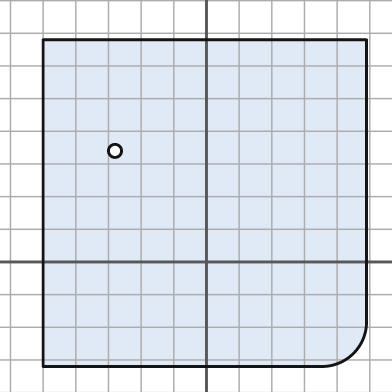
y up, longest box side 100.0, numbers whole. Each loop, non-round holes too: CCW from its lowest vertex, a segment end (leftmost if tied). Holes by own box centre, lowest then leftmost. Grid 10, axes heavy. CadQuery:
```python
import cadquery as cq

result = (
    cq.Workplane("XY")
    .moveTo(-50.0, -32.0)
    .lineTo(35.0, -32.0)
    .threePointArc((45.0, -28.0), (49.0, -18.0))
    .lineTo(49.0, 68.0)
    .lineTo(-50.0, 68.0)
    .close()
    .moveTo(-28.0, 34.0)
    .circle(2.0)
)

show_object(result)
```